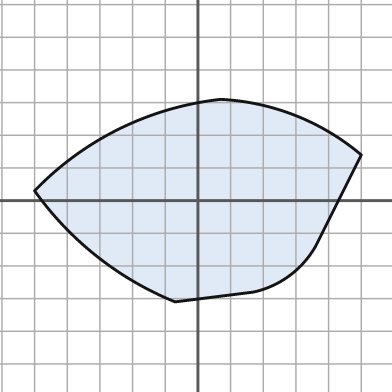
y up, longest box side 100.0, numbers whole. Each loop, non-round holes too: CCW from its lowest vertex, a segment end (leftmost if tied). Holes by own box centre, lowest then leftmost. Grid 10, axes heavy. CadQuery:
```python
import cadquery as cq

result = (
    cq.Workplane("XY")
    .moveTo(-7.0, -31.0)
    .lineTo(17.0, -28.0)
    .threePointArc((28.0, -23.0), (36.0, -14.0))
    .lineTo(50.0, 14.0)
    .threePointArc((30.0, 26.0), (7.0, 31.0))
    .threePointArc((-24.0, 22.0), (-50.0, 3.0))
    .threePointArc((-31.0, -17.0), (-7.0, -31.0))
    .close()
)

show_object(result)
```